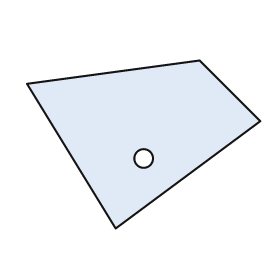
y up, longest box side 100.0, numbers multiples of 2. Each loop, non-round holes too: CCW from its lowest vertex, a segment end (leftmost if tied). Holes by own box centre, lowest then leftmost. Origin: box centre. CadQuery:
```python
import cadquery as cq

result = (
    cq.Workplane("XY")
    .moveTo(-12.0, -36.0)
    .lineTo(50.0, 10.0)
    .lineTo(24.0, 36.0)
    .lineTo(-50.0, 26.0)
    .close()
    .moveTo(0.0, -6.0)
    .circle(4.0)
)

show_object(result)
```